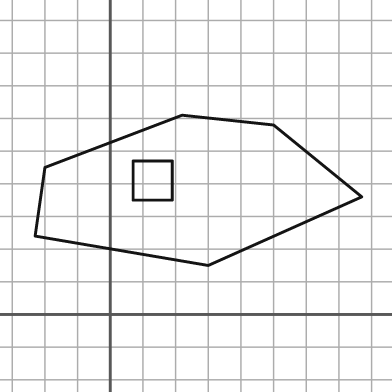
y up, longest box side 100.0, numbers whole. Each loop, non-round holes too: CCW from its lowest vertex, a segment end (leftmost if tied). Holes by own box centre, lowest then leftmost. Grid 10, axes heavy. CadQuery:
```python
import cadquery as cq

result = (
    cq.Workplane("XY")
    .moveTo(30.0, 15.0)
    .lineTo(77.0, 36.0)
    .lineTo(50.0, 58.0)
    .lineTo(22.0, 61.0)
    .lineTo(-20.0, 45.0)
    .lineTo(-23.0, 24.0)
    .close()
    .moveTo(7.0, 35.0)
    .lineTo(19.0, 35.0)
    .lineTo(19.0, 47.0)
    .lineTo(7.0, 47.0)
    .close()
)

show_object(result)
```